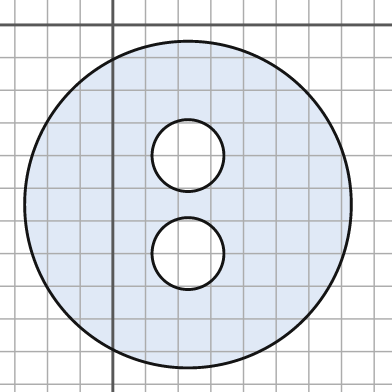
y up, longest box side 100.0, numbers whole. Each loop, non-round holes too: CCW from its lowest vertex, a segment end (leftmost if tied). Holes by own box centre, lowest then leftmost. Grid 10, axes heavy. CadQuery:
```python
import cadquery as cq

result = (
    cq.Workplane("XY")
    .moveTo(23.0, -55.0)
    .circle(50.0)
    .moveTo(23.0, -70.0)
    .circle(11.0)
    .moveTo(23.0, -40.0)
    .circle(11.0)
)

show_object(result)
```